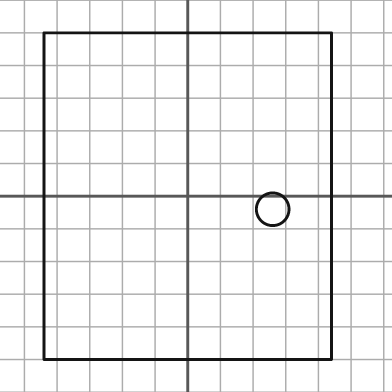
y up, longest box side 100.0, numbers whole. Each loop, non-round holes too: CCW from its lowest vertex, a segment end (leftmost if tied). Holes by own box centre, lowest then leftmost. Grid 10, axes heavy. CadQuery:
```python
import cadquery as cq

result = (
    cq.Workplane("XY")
    .moveTo(-44.0, -50.0)
    .lineTo(44.0, -50.0)
    .lineTo(44.0, 50.0)
    .lineTo(-44.0, 50.0)
    .close()
    .moveTo(26.0, -4.0)
    .circle(5.0)
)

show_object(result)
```